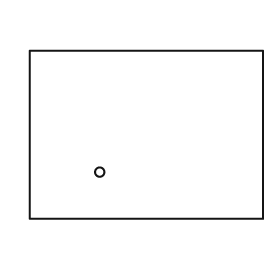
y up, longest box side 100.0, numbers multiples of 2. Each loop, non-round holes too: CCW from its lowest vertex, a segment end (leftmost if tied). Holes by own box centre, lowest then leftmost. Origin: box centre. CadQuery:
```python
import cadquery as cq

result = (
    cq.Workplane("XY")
    .moveTo(-50.0, -36.0)
    .lineTo(50.0, -36.0)
    .lineTo(50.0, 36.0)
    .lineTo(-50.0, 36.0)
    .close()
    .moveTo(-20.0, -16.0)
    .circle(2.0)
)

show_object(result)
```